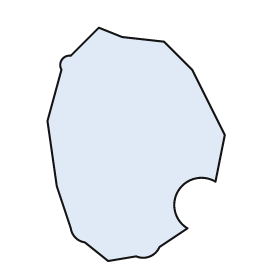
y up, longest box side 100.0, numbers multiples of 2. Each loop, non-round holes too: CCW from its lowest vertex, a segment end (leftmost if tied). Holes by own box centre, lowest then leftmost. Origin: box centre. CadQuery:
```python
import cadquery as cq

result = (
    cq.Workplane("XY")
    .moveTo(-12.0, -50.0)
    .lineTo(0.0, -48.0)
    .threePointArc((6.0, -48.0), (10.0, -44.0))
    .lineTo(22.0, -36.0)
    .threePointArc((18.0, -20.0), (34.0, -16.0))
    .lineTo(38.0, 4.0)
    .lineTo(24.0, 32.0)
    .lineTo(12.0, 44.0)
    .lineTo(-6.0, 46.0)
    .lineTo(-16.0, 50.0)
    .lineTo(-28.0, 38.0)
    .threePointArc((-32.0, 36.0), (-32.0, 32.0))
    .lineTo(-38.0, 10.0)
    .lineTo(-34.0, -18.0)
    .lineTo(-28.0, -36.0)
    .threePointArc((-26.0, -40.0), (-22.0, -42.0))
    .close()
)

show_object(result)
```